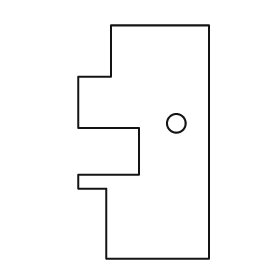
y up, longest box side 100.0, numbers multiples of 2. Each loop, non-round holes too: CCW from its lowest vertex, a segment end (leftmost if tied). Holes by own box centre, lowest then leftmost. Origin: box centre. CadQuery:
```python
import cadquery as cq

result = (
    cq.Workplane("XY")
    .moveTo(-16.0, -50.0)
    .lineTo(28.0, -50.0)
    .lineTo(28.0, 50.0)
    .lineTo(-14.0, 50.0)
    .lineTo(-14.0, 28.0)
    .lineTo(-28.0, 28.0)
    .lineTo(-28.0, 6.0)
    .lineTo(-2.0, 6.0)
    .lineTo(-2.0, -14.0)
    .lineTo(-28.0, -14.0)
    .lineTo(-28.0, -20.0)
    .lineTo(-16.0, -20.0)
    .close()
    .moveTo(14.0, 8.0)
    .circle(4.0)
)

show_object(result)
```